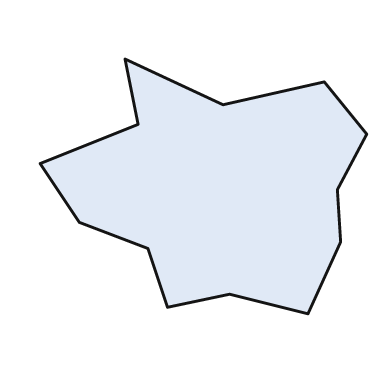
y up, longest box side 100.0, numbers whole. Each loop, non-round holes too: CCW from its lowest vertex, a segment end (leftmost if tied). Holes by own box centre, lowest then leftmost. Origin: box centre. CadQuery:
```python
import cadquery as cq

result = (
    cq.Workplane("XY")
    .moveTo(32.0, -39.0)
    .lineTo(42.0, -17.0)
    .lineTo(41.0, -1.0)
    .lineTo(50.0, 16.0)
    .lineTo(37.0, 32.0)
    .lineTo(6.0, 25.0)
    .lineTo(-24.0, 39.0)
    .lineTo(-20.0, 19.0)
    .lineTo(-50.0, 7.0)
    .lineTo(-38.0, -11.0)
    .lineTo(-17.0, -19.0)
    .lineTo(-11.0, -37.0)
    .lineTo(8.0, -33.0)
    .close()
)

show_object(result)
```